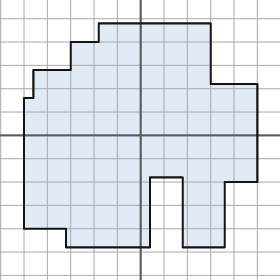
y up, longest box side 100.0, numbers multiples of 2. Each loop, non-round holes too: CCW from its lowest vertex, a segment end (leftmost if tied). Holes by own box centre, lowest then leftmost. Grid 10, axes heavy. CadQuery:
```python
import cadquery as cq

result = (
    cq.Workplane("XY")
    .moveTo(-32.0, -48.0)
    .lineTo(4.0, -48.0)
    .lineTo(4.0, -18.0)
    .lineTo(18.0, -18.0)
    .lineTo(18.0, -48.0)
    .lineTo(36.0, -48.0)
    .lineTo(36.0, -20.0)
    .lineTo(50.0, -20.0)
    .lineTo(50.0, 22.0)
    .lineTo(30.0, 22.0)
    .lineTo(30.0, 48.0)
    .lineTo(-18.0, 48.0)
    .lineTo(-18.0, 40.0)
    .lineTo(-30.0, 40.0)
    .lineTo(-30.0, 28.0)
    .lineTo(-46.0, 28.0)
    .lineTo(-46.0, 16.0)
    .lineTo(-50.0, 16.0)
    .lineTo(-50.0, -40.0)
    .lineTo(-32.0, -40.0)
    .close()
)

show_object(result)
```